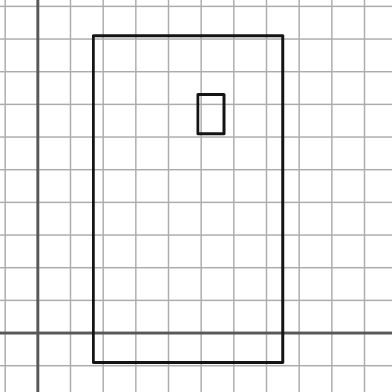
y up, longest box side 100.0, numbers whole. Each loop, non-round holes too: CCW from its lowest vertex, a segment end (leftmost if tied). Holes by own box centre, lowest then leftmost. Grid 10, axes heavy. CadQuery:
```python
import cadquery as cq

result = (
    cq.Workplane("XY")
    .moveTo(17.0, -9.0)
    .lineTo(75.0, -9.0)
    .lineTo(75.0, 91.0)
    .lineTo(17.0, 91.0)
    .close()
    .moveTo(49.0, 61.0)
    .lineTo(57.0, 61.0)
    .lineTo(57.0, 73.0)
    .lineTo(49.0, 73.0)
    .close()
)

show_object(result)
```